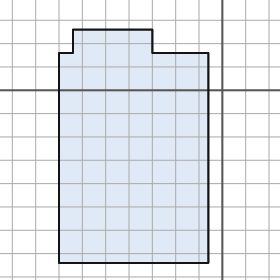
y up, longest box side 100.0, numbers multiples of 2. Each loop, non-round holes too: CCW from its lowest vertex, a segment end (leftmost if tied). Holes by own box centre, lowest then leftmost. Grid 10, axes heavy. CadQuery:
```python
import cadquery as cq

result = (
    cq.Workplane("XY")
    .moveTo(-70.0, -74.0)
    .lineTo(-6.0, -74.0)
    .lineTo(-6.0, 16.0)
    .lineTo(-30.0, 16.0)
    .lineTo(-30.0, 26.0)
    .lineTo(-64.0, 26.0)
    .lineTo(-64.0, 16.0)
    .lineTo(-70.0, 16.0)
    .close()
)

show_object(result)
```